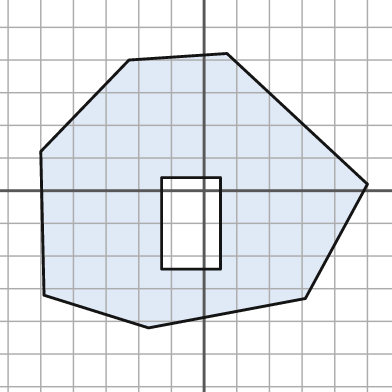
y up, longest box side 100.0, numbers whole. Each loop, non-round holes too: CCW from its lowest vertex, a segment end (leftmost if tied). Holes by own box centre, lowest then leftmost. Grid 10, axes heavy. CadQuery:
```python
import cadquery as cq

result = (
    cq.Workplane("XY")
    .moveTo(-17.0, -42.0)
    .lineTo(31.0, -33.0)
    .lineTo(50.0, 2.0)
    .lineTo(7.0, 42.0)
    .lineTo(-23.0, 40.0)
    .lineTo(-50.0, 12.0)
    .lineTo(-49.0, -32.0)
    .close()
    .moveTo(-13.0, -24.0)
    .lineTo(5.0, -24.0)
    .lineTo(5.0, 4.0)
    .lineTo(-13.0, 4.0)
    .close()
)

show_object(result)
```